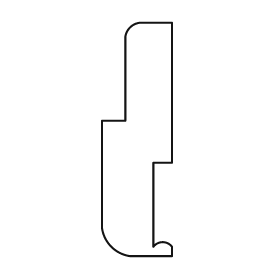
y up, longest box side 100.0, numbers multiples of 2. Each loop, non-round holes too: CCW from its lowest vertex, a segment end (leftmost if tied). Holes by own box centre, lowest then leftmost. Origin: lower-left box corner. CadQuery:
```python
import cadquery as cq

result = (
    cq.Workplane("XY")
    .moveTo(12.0, 0.0)
    .lineTo(30.0, 0.0)
    .lineTo(30.0, 4.0)
    .threePointArc((26.0, 6.0), (22.0, 4.0))
    .lineTo(22.0, 40.0)
    .lineTo(30.0, 40.0)
    .lineTo(30.0, 100.0)
    .lineTo(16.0, 100.0)
    .threePointArc((12.0, 98.0), (10.0, 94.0))
    .lineTo(10.0, 58.0)
    .lineTo(0.0, 58.0)
    .lineTo(0.0, 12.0)
    .threePointArc((4.0, 4.0), (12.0, 0.0))
    .close()
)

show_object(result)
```